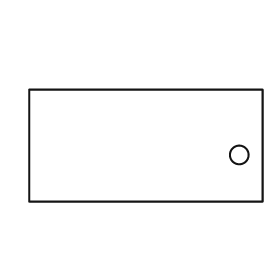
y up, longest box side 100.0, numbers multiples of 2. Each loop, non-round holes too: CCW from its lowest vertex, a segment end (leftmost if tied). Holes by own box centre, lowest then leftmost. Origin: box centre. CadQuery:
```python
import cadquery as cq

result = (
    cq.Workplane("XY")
    .moveTo(-50.0, -24.0)
    .lineTo(50.0, -24.0)
    .lineTo(50.0, 24.0)
    .lineTo(-50.0, 24.0)
    .close()
    .moveTo(40.0, -4.0)
    .circle(4.0)
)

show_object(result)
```